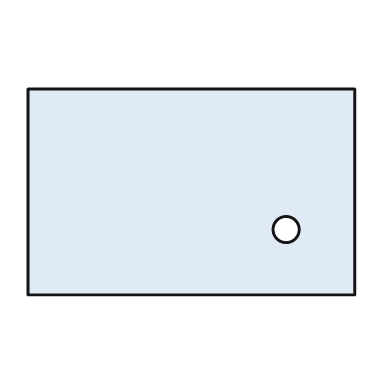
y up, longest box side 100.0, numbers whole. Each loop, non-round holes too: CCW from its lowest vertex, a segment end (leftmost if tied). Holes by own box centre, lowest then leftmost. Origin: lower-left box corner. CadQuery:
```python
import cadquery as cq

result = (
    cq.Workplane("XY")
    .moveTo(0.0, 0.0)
    .lineTo(100.0, 0.0)
    .lineTo(100.0, 63.0)
    .lineTo(0.0, 63.0)
    .close()
    .moveTo(79.0, 20.0)
    .circle(4.0)
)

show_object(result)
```